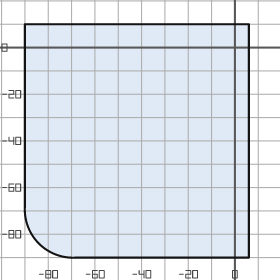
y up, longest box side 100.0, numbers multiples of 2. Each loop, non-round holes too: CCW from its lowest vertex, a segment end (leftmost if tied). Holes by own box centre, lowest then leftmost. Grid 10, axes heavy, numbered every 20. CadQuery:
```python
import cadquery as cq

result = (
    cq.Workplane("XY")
    .moveTo(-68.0, -90.0)
    .lineTo(6.0, -90.0)
    .lineTo(6.0, 10.0)
    .lineTo(-90.0, 10.0)
    .lineTo(-90.0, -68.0)
    .threePointArc((-84.0, -84.0), (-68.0, -90.0))
    .close()
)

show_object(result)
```